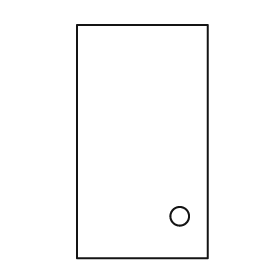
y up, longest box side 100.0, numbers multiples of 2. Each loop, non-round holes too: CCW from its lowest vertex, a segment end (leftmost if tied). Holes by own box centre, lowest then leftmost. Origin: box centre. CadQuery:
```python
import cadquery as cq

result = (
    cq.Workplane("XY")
    .moveTo(-28.0, -50.0)
    .lineTo(28.0, -50.0)
    .lineTo(28.0, 50.0)
    .lineTo(-28.0, 50.0)
    .close()
    .moveTo(16.0, -32.0)
    .circle(4.0)
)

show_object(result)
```